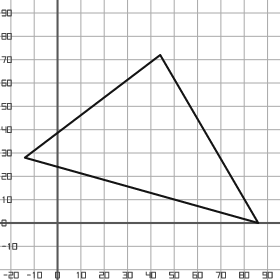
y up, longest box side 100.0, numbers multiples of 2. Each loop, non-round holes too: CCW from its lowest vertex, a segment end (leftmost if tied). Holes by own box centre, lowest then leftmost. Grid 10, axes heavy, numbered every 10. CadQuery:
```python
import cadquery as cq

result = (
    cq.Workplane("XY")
    .moveTo(86.0, 0.0)
    .lineTo(44.0, 72.0)
    .lineTo(-14.0, 28.0)
    .close()
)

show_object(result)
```